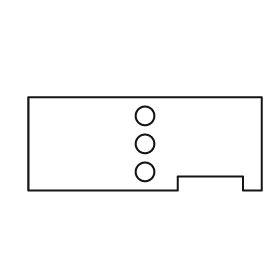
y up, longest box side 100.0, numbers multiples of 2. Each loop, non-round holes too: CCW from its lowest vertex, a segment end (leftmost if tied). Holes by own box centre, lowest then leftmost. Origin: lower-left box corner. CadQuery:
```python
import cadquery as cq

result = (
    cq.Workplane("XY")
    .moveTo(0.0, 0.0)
    .lineTo(64.0, 0.0)
    .lineTo(64.0, 6.0)
    .lineTo(92.0, 6.0)
    .lineTo(92.0, 0.0)
    .lineTo(100.0, 0.0)
    .lineTo(100.0, 40.0)
    .lineTo(0.0, 40.0)
    .close()
    .moveTo(50.0, 8.0)
    .circle(4.0)
    .moveTo(50.0, 20.0)
    .circle(4.0)
    .moveTo(50.0, 32.0)
    .circle(4.0)
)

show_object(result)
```